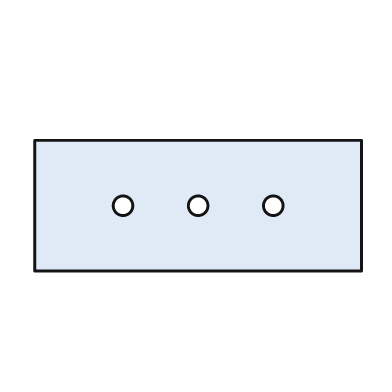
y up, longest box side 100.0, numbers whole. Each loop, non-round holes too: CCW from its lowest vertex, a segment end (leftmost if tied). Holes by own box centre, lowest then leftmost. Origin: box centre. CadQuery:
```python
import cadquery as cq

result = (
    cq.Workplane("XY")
    .moveTo(-50.0, -20.0)
    .lineTo(50.0, -20.0)
    .lineTo(50.0, 20.0)
    .lineTo(-50.0, 20.0)
    .close()
    .moveTo(-23.0, 0.0)
    .circle(3.0)
    .moveTo(0.0, 0.0)
    .circle(3.0)
    .moveTo(23.0, 0.0)
    .circle(3.0)
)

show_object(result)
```